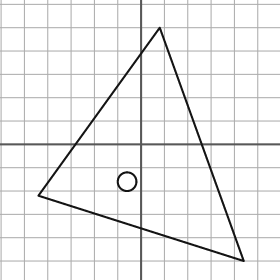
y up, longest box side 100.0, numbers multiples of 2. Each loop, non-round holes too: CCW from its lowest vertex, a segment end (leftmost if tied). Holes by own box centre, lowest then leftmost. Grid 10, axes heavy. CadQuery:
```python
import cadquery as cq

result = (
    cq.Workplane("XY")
    .moveTo(44.0, -50.0)
    .lineTo(8.0, 50.0)
    .lineTo(-44.0, -22.0)
    .close()
    .moveTo(-6.0, -16.0)
    .circle(4.0)
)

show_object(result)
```